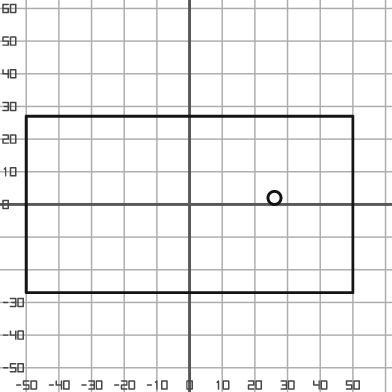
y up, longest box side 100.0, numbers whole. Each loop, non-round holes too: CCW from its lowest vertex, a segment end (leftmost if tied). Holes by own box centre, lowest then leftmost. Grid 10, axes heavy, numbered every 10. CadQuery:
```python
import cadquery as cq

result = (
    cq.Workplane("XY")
    .moveTo(-50.0, -27.0)
    .lineTo(50.0, -27.0)
    .lineTo(50.0, 27.0)
    .lineTo(-50.0, 27.0)
    .close()
    .moveTo(26.0, 2.0)
    .circle(2.0)
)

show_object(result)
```